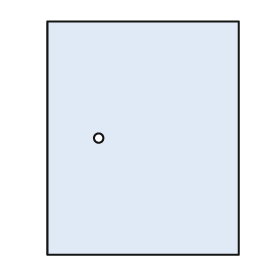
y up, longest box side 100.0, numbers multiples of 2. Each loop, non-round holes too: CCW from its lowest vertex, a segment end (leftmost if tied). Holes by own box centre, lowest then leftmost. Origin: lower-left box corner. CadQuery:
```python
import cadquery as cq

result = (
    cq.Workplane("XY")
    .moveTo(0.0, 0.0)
    .lineTo(82.0, 0.0)
    .lineTo(82.0, 100.0)
    .lineTo(0.0, 100.0)
    .close()
    .moveTo(22.0, 50.0)
    .circle(2.0)
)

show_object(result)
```